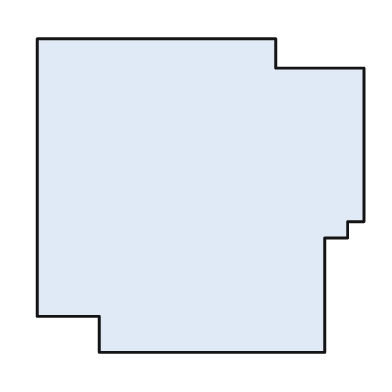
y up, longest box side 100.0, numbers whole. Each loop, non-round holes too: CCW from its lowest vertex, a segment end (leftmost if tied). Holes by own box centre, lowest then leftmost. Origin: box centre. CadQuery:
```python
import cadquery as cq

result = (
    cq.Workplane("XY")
    .moveTo(-31.0, -48.0)
    .lineTo(38.0, -48.0)
    .lineTo(38.0, -13.0)
    .lineTo(45.0, -13.0)
    .lineTo(45.0, -8.0)
    .lineTo(50.0, -8.0)
    .lineTo(50.0, 39.0)
    .lineTo(23.0, 39.0)
    .lineTo(23.0, 48.0)
    .lineTo(-50.0, 48.0)
    .lineTo(-50.0, -37.0)
    .lineTo(-31.0, -37.0)
    .close()
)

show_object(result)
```